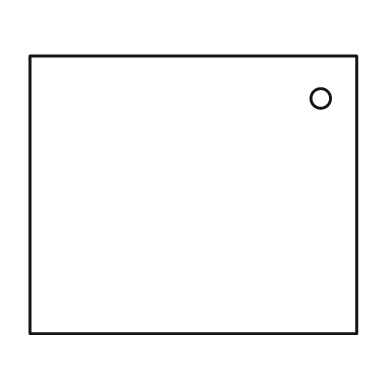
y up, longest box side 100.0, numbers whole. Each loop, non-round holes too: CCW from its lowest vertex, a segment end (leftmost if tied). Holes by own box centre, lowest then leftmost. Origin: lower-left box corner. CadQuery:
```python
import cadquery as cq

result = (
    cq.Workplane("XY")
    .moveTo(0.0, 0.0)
    .lineTo(100.0, 0.0)
    .lineTo(100.0, 85.0)
    .lineTo(0.0, 85.0)
    .close()
    .moveTo(89.0, 72.0)
    .circle(3.0)
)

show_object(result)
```